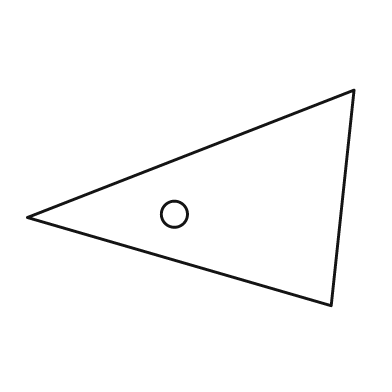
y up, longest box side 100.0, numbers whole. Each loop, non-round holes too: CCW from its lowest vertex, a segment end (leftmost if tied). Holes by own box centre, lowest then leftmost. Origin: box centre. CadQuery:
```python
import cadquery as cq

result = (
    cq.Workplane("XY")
    .moveTo(43.0, -33.0)
    .lineTo(50.0, 33.0)
    .lineTo(-50.0, -6.0)
    .close()
    .moveTo(-5.0, -5.0)
    .circle(4.0)
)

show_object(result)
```